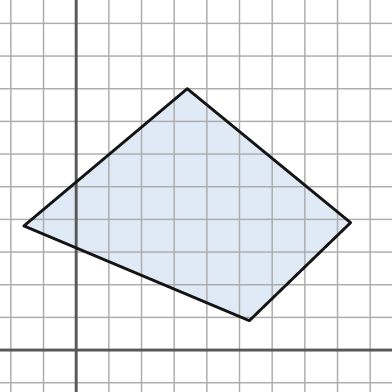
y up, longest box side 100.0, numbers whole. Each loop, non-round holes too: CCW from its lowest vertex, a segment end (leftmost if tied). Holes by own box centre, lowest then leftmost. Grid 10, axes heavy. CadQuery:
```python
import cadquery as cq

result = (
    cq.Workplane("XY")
    .moveTo(53.0, 9.0)
    .lineTo(84.0, 39.0)
    .lineTo(34.0, 80.0)
    .lineTo(-16.0, 38.0)
    .close()
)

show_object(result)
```